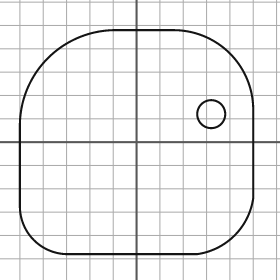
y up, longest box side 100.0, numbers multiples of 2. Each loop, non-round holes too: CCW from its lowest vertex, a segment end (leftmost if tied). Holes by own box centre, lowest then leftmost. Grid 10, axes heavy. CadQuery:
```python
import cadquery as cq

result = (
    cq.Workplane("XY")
    .moveTo(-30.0, -48.0)
    .lineTo(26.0, -48.0)
    .threePointArc((42.0, -40.0), (50.0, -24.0))
    .lineTo(50.0, 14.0)
    .threePointArc((40.0, 38.0), (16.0, 48.0))
    .lineTo(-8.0, 48.0)
    .threePointArc((-38.0, 36.0), (-50.0, 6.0))
    .lineTo(-50.0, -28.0)
    .threePointArc((-44.0, -42.0), (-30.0, -48.0))
    .close()
    .moveTo(32.0, 12.0)
    .circle(6.0)
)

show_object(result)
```